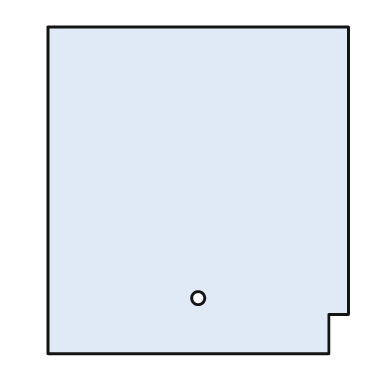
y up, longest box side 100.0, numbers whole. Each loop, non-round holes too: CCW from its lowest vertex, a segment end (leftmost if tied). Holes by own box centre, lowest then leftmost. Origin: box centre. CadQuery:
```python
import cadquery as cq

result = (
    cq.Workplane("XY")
    .moveTo(-46.0, -50.0)
    .lineTo(40.0, -50.0)
    .lineTo(40.0, -38.0)
    .lineTo(46.0, -38.0)
    .lineTo(46.0, 50.0)
    .lineTo(-46.0, 50.0)
    .close()
    .moveTo(0.0, -33.0)
    .circle(2.0)
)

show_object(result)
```